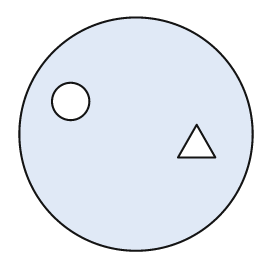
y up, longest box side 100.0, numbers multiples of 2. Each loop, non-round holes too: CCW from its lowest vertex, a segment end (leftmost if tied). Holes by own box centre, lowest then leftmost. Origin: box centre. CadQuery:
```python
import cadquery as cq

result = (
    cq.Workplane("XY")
    .moveTo(0.0, 0.0)
    .circle(50.0)
    .moveTo(18.0, -10.0)
    .lineTo(34.0, -10.0)
    .lineTo(26.0, 4.0)
    .close()
    .moveTo(-28.0, 14.0)
    .circle(8.0)
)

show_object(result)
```